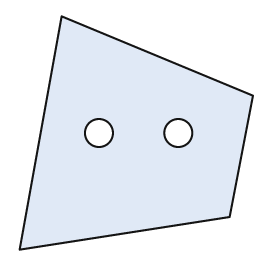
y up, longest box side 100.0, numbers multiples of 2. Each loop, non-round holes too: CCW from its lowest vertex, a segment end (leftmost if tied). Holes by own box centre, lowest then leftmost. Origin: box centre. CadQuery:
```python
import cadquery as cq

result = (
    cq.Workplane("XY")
    .moveTo(-50.0, -50.0)
    .lineTo(40.0, -36.0)
    .lineTo(50.0, 16.0)
    .lineTo(-32.0, 50.0)
    .close()
    .moveTo(-16.0, 0.0)
    .circle(6.0)
    .moveTo(18.0, 0.0)
    .circle(6.0)
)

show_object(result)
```